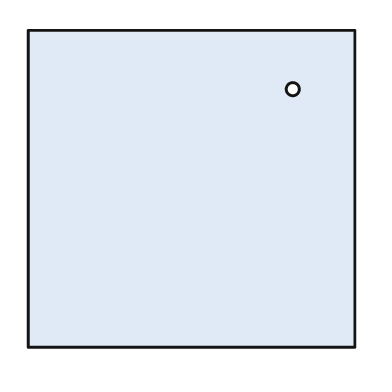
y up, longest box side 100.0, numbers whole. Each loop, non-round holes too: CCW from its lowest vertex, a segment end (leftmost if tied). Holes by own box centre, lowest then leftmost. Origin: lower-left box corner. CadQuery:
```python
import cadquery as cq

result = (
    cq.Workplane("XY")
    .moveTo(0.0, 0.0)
    .lineTo(100.0, 0.0)
    .lineTo(100.0, 97.0)
    .lineTo(0.0, 97.0)
    .close()
    .moveTo(81.0, 79.0)
    .circle(2.0)
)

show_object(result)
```